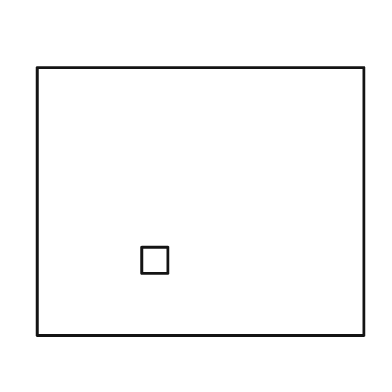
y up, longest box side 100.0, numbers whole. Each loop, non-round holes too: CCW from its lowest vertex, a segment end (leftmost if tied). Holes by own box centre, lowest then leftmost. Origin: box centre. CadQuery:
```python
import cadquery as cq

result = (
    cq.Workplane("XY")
    .moveTo(-50.0, -41.0)
    .lineTo(50.0, -41.0)
    .lineTo(50.0, 41.0)
    .lineTo(-50.0, 41.0)
    .close()
    .moveTo(-18.0, -22.0)
    .lineTo(-10.0, -22.0)
    .lineTo(-10.0, -14.0)
    .lineTo(-18.0, -14.0)
    .close()
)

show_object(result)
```